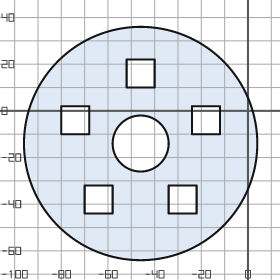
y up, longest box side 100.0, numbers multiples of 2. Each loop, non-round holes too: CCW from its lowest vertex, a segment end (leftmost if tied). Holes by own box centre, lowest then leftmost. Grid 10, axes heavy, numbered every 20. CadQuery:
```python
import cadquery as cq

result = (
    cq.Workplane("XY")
    .moveTo(-46.0, -14.0)
    .circle(50.0)
    .moveTo(-70.0, -44.0)
    .lineTo(-58.0, -44.0)
    .lineTo(-58.0, -32.0)
    .lineTo(-70.0, -32.0)
    .close()
    .moveTo(-34.0, -44.0)
    .lineTo(-22.0, -44.0)
    .lineTo(-22.0, -32.0)
    .lineTo(-34.0, -32.0)
    .close()
    .moveTo(-46.0, -14.0)
    .circle(12.0)
    .moveTo(-80.0, -10.0)
    .lineTo(-68.0, -10.0)
    .lineTo(-68.0, 2.0)
    .lineTo(-80.0, 2.0)
    .close()
    .moveTo(-24.0, -10.0)
    .lineTo(-12.0, -10.0)
    .lineTo(-12.0, 2.0)
    .lineTo(-24.0, 2.0)
    .close()
    .moveTo(-52.0, 10.0)
    .lineTo(-40.0, 10.0)
    .lineTo(-40.0, 22.0)
    .lineTo(-52.0, 22.0)
    .close()
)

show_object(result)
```